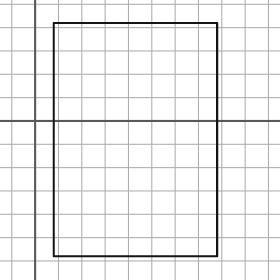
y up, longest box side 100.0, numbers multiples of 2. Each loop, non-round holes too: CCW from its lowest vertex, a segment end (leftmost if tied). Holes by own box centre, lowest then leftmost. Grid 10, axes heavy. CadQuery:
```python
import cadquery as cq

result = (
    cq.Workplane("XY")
    .moveTo(8.0, -58.0)
    .lineTo(78.0, -58.0)
    .lineTo(78.0, 42.0)
    .lineTo(8.0, 42.0)
    .close()
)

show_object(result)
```